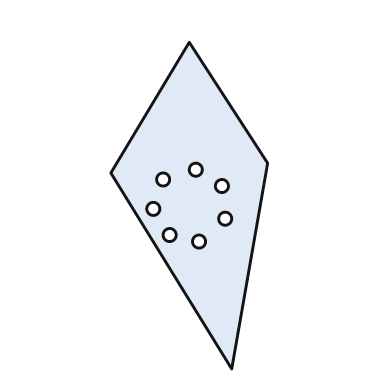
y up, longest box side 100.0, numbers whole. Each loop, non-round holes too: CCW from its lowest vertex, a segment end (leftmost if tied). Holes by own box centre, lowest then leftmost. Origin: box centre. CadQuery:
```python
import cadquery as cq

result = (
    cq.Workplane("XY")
    .moveTo(13.0, -50.0)
    .lineTo(24.0, 13.0)
    .lineTo(0.0, 50.0)
    .lineTo(-24.0, 10.0)
    .close()
    .moveTo(3.0, -11.0)
    .circle(2.0)
    .moveTo(-6.0, -9.0)
    .circle(2.0)
    .moveTo(11.0, -4.0)
    .circle(2.0)
    .moveTo(-11.0, -1.0)
    .circle(2.0)
    .moveTo(10.0, 6.0)
    .circle(2.0)
    .moveTo(-8.0, 8.0)
    .circle(2.0)
    .moveTo(2.0, 11.0)
    .circle(2.0)
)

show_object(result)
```